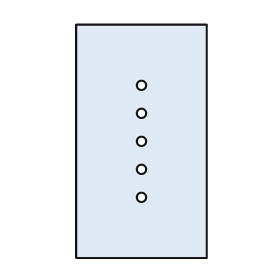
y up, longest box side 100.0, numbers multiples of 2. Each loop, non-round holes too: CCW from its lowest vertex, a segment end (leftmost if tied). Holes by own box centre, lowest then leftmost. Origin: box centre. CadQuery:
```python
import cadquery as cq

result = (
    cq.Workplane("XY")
    .moveTo(-28.0, -50.0)
    .lineTo(28.0, -50.0)
    .lineTo(28.0, 50.0)
    .lineTo(-28.0, 50.0)
    .close()
    .moveTo(0.0, -24.0)
    .circle(2.0)
    .moveTo(0.0, -12.0)
    .circle(2.0)
    .moveTo(0.0, 0.0)
    .circle(2.0)
    .moveTo(0.0, 12.0)
    .circle(2.0)
    .moveTo(0.0, 24.0)
    .circle(2.0)
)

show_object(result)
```